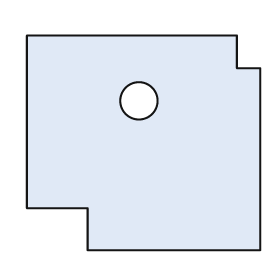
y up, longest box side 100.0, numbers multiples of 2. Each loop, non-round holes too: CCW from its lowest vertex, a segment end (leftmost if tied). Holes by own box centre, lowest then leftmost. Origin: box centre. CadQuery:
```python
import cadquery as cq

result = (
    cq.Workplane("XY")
    .moveTo(-24.0, -46.0)
    .lineTo(50.0, -46.0)
    .lineTo(50.0, 32.0)
    .lineTo(40.0, 32.0)
    .lineTo(40.0, 46.0)
    .lineTo(-50.0, 46.0)
    .lineTo(-50.0, -28.0)
    .lineTo(-24.0, -28.0)
    .close()
    .moveTo(-2.0, 18.0)
    .circle(8.0)
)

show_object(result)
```